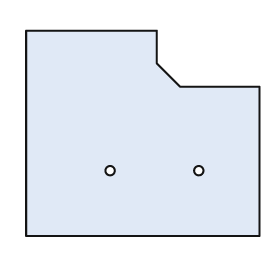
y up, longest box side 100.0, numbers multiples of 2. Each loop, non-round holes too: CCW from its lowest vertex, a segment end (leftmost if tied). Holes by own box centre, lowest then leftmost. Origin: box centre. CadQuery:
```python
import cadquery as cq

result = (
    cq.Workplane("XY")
    .moveTo(-50.0, -44.0)
    .lineTo(50.0, -44.0)
    .lineTo(50.0, 20.0)
    .lineTo(16.0, 20.0)
    .lineTo(6.0, 30.0)
    .lineTo(6.0, 44.0)
    .lineTo(-50.0, 44.0)
    .close()
    .moveTo(-14.0, -16.0)
    .circle(2.0)
    .moveTo(24.0, -16.0)
    .circle(2.0)
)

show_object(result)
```